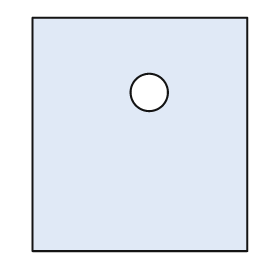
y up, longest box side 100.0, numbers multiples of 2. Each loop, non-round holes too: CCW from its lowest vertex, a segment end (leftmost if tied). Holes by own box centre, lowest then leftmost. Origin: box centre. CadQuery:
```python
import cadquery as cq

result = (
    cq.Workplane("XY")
    .moveTo(-46.0, -50.0)
    .lineTo(46.0, -50.0)
    .lineTo(46.0, 50.0)
    .lineTo(-46.0, 50.0)
    .close()
    .moveTo(4.0, 18.0)
    .circle(8.0)
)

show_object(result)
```